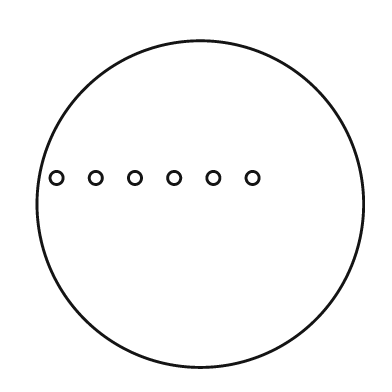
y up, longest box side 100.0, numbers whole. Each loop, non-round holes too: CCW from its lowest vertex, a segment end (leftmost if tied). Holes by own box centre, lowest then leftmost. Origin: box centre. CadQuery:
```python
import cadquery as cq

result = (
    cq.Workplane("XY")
    .moveTo(0.0, 0.0)
    .circle(50.0)
    .moveTo(-44.0, 8.0)
    .circle(2.0)
    .moveTo(-32.0, 8.0)
    .circle(2.0)
    .moveTo(-20.0, 8.0)
    .circle(2.0)
    .moveTo(-8.0, 8.0)
    .circle(2.0)
    .moveTo(4.0, 8.0)
    .circle(2.0)
    .moveTo(16.0, 8.0)
    .circle(2.0)
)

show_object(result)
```